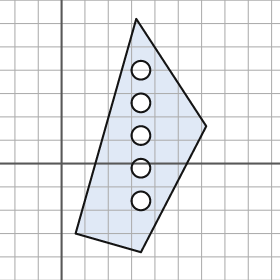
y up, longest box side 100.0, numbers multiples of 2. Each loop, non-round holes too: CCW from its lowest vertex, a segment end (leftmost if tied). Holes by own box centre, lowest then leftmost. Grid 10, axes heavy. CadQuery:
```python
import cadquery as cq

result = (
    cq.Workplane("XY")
    .moveTo(34.0, -38.0)
    .lineTo(62.0, 16.0)
    .lineTo(32.0, 62.0)
    .lineTo(6.0, -30.0)
    .close()
    .moveTo(34.0, -16.0)
    .circle(4.0)
    .moveTo(34.0, -2.0)
    .circle(4.0)
    .moveTo(34.0, 12.0)
    .circle(4.0)
    .moveTo(34.0, 26.0)
    .circle(4.0)
    .moveTo(34.0, 40.0)
    .circle(4.0)
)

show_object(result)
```